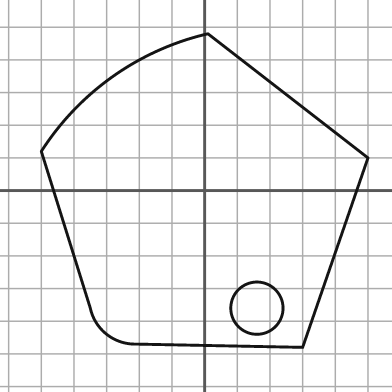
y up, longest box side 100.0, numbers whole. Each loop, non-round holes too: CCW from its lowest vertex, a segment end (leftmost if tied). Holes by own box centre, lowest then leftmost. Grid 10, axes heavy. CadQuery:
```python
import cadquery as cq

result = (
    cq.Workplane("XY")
    .moveTo(30.0, -48.0)
    .lineTo(50.0, 10.0)
    .lineTo(1.0, 48.0)
    .threePointArc((-28.0, 35.0), (-50.0, 12.0))
    .lineTo(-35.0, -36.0)
    .threePointArc((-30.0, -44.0), (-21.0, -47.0))
    .close()
    .moveTo(16.0, -36.0)
    .circle(8.0)
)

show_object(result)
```